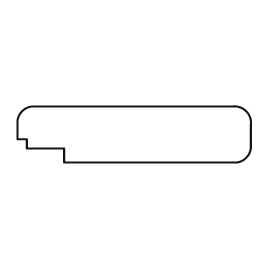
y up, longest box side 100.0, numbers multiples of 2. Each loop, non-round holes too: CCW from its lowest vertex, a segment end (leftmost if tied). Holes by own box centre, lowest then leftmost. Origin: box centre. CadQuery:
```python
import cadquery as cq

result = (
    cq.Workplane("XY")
    .moveTo(-30.0, -12.0)
    .lineTo(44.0, -12.0)
    .threePointArc((48.0, -10.0), (50.0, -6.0))
    .lineTo(50.0, 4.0)
    .threePointArc((48.0, 10.0), (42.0, 12.0))
    .lineTo(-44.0, 12.0)
    .threePointArc((-48.0, 10.0), (-50.0, 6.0))
    .lineTo(-50.0, -2.0)
    .lineTo(-46.0, -2.0)
    .lineTo(-46.0, -6.0)
    .lineTo(-30.0, -6.0)
    .close()
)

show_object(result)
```